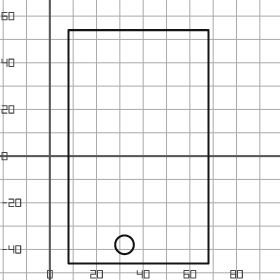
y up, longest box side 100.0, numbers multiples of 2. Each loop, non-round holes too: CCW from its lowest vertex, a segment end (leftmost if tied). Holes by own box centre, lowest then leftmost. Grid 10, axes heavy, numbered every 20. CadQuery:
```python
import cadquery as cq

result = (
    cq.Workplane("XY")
    .moveTo(8.0, -46.0)
    .lineTo(68.0, -46.0)
    .lineTo(68.0, 54.0)
    .lineTo(8.0, 54.0)
    .close()
    .moveTo(32.0, -38.0)
    .circle(4.0)
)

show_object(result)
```